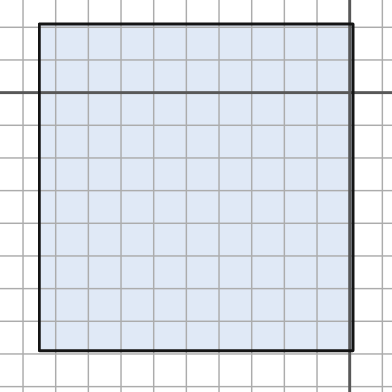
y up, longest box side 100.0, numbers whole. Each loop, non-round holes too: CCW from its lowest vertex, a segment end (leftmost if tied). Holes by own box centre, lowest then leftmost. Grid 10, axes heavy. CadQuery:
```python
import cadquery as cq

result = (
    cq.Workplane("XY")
    .moveTo(-95.0, -79.0)
    .lineTo(1.0, -79.0)
    .lineTo(1.0, 21.0)
    .lineTo(-95.0, 21.0)
    .close()
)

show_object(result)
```